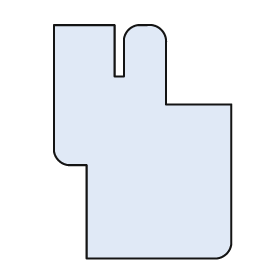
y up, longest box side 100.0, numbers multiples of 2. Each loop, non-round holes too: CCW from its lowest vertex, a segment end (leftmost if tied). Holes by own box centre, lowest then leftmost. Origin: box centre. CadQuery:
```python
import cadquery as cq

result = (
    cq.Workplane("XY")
    .moveTo(-24.0, -50.0)
    .lineTo(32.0, -50.0)
    .threePointArc((36.0, -48.0), (38.0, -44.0))
    .lineTo(38.0, 16.0)
    .lineTo(10.0, 16.0)
    .lineTo(10.0, 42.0)
    .threePointArc((8.0, 48.0), (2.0, 50.0))
    .lineTo(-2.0, 50.0)
    .threePointArc((-6.0, 48.0), (-8.0, 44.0))
    .lineTo(-8.0, 28.0)
    .lineTo(-12.0, 28.0)
    .lineTo(-12.0, 50.0)
    .lineTo(-38.0, 50.0)
    .lineTo(-38.0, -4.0)
    .threePointArc((-36.0, -8.0), (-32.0, -10.0))
    .lineTo(-24.0, -10.0)
    .close()
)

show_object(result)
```